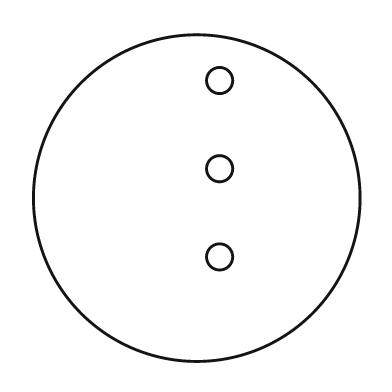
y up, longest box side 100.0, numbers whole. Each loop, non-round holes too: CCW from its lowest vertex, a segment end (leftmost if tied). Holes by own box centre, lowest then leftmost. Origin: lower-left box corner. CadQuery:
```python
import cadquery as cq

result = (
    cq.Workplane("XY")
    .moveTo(50.0, 50.0)
    .circle(50.0)
    .moveTo(57.0, 32.0)
    .circle(4.0)
    .moveTo(57.0, 59.0)
    .circle(4.0)
    .moveTo(57.0, 86.0)
    .circle(4.0)
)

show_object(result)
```